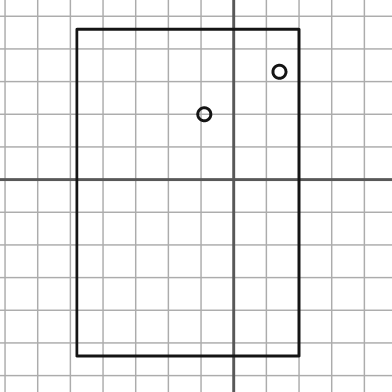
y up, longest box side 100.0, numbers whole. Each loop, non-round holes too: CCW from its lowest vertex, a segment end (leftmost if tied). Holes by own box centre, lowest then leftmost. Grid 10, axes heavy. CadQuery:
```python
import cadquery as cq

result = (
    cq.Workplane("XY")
    .moveTo(-48.0, -54.0)
    .lineTo(20.0, -54.0)
    .lineTo(20.0, 46.0)
    .lineTo(-48.0, 46.0)
    .close()
    .moveTo(-9.0, 20.0)
    .circle(2.0)
    .moveTo(14.0, 33.0)
    .circle(2.0)
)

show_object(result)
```